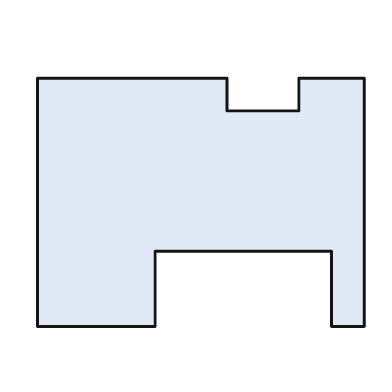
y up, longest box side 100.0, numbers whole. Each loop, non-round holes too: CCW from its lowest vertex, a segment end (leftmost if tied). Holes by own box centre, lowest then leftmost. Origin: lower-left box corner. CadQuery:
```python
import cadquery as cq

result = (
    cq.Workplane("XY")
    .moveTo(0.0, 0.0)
    .lineTo(36.0, 0.0)
    .lineTo(36.0, 23.0)
    .lineTo(90.0, 23.0)
    .lineTo(90.0, 0.0)
    .lineTo(100.0, 0.0)
    .lineTo(100.0, 76.0)
    .lineTo(80.0, 76.0)
    .lineTo(80.0, 66.0)
    .lineTo(58.0, 66.0)
    .lineTo(58.0, 76.0)
    .lineTo(0.0, 76.0)
    .close()
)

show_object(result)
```